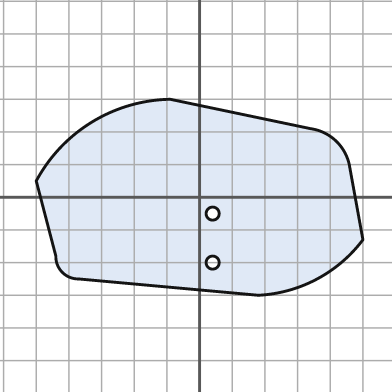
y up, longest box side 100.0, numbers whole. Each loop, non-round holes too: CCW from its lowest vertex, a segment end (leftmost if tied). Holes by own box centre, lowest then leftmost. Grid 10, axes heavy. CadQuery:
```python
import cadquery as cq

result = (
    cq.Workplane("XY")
    .moveTo(18.0, -30.0)
    .threePointArc((36.0, -25.0), (50.0, -13.0))
    .lineTo(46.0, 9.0)
    .threePointArc((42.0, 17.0), (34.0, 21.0))
    .lineTo(-9.0, 30.0)
    .threePointArc((-33.0, 23.0), (-50.0, 5.0))
    .lineTo(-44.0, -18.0)
    .threePointArc((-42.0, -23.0), (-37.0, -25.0))
    .close()
    .moveTo(4.0, -20.0)
    .circle(2.0)
    .moveTo(4.0, -5.0)
    .circle(2.0)
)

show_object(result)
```